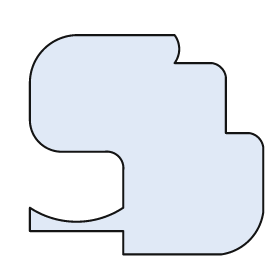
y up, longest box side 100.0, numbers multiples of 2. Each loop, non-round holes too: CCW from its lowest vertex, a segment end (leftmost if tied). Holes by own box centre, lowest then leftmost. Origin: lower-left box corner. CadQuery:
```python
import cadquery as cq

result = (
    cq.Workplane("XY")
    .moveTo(40.0, 0.0)
    .lineTo(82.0, 0.0)
    .threePointArc((94.0, 6.0), (100.0, 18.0))
    .lineTo(100.0, 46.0)
    .threePointArc((98.0, 50.0), (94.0, 52.0))
    .lineTo(84.0, 52.0)
    .lineTo(84.0, 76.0)
    .threePointArc((82.0, 80.0), (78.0, 82.0))
    .lineTo(62.0, 82.0)
    .threePointArc((64.0, 88.0), (62.0, 94.0))
    .lineTo(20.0, 94.0)
    .threePointArc((6.0, 88.0), (0.0, 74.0))
    .lineTo(0.0, 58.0)
    .threePointArc((4.0, 48.0), (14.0, 44.0))
    .lineTo(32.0, 44.0)
    .threePointArc((38.0, 42.0), (40.0, 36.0))
    .lineTo(40.0, 20.0)
    .threePointArc((20.0, 14.0), (0.0, 20.0))
    .lineTo(0.0, 10.0)
    .lineTo(40.0, 10.0)
    .close()
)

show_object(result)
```